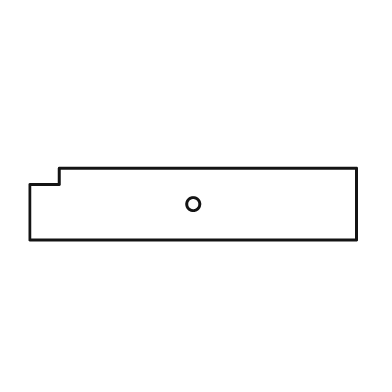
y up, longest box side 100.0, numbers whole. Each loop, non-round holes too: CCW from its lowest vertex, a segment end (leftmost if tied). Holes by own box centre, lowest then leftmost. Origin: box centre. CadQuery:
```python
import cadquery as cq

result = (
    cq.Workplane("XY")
    .moveTo(-50.0, -11.0)
    .lineTo(50.0, -11.0)
    .lineTo(50.0, 11.0)
    .lineTo(-41.0, 11.0)
    .lineTo(-41.0, 6.0)
    .lineTo(-50.0, 6.0)
    .close()
    .moveTo(0.0, 0.0)
    .circle(2.0)
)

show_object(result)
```